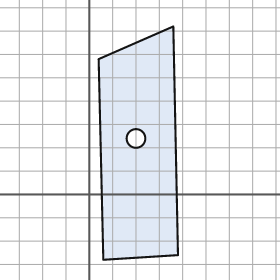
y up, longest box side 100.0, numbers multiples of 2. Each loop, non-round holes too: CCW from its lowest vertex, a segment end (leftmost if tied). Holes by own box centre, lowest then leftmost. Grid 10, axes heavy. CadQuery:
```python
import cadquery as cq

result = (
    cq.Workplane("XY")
    .moveTo(6.0, -28.0)
    .lineTo(38.0, -26.0)
    .lineTo(36.0, 72.0)
    .lineTo(4.0, 58.0)
    .close()
    .moveTo(20.0, 24.0)
    .circle(4.0)
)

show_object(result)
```